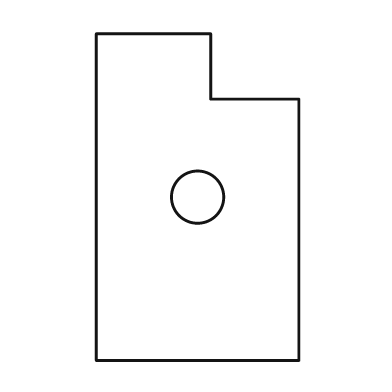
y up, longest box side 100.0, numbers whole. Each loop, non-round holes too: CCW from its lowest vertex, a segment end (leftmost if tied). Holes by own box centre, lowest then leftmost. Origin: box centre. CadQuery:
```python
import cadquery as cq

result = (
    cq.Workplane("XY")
    .moveTo(-31.0, -50.0)
    .lineTo(31.0, -50.0)
    .lineTo(31.0, 30.0)
    .lineTo(4.0, 30.0)
    .lineTo(4.0, 50.0)
    .lineTo(-31.0, 50.0)
    .close()
    .moveTo(0.0, 0.0)
    .circle(8.0)
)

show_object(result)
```